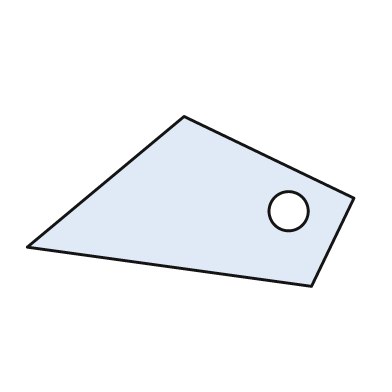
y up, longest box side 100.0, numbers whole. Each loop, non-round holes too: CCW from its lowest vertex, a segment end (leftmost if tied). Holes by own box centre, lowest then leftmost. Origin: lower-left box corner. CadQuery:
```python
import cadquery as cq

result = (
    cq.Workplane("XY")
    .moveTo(87.0, 0.0)
    .lineTo(100.0, 27.0)
    .lineTo(48.0, 52.0)
    .lineTo(0.0, 12.0)
    .close()
    .moveTo(80.0, 23.0)
    .circle(6.0)
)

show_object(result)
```